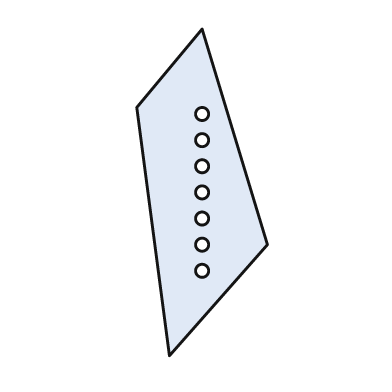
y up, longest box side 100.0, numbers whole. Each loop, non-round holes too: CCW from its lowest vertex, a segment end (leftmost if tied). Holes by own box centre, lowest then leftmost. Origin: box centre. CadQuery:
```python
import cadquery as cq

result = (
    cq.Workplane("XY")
    .moveTo(-10.0, -50.0)
    .lineTo(20.0, -16.0)
    .lineTo(0.0, 50.0)
    .lineTo(-20.0, 26.0)
    .close()
    .moveTo(0.0, -24.0)
    .circle(2.0)
    .moveTo(0.0, -16.0)
    .circle(2.0)
    .moveTo(0.0, -8.0)
    .circle(2.0)
    .moveTo(0.0, 0.0)
    .circle(2.0)
    .moveTo(0.0, 8.0)
    .circle(2.0)
    .moveTo(0.0, 16.0)
    .circle(2.0)
    .moveTo(0.0, 24.0)
    .circle(2.0)
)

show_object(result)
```